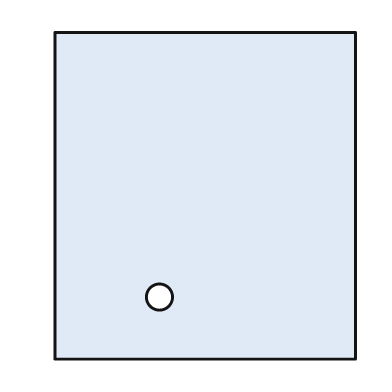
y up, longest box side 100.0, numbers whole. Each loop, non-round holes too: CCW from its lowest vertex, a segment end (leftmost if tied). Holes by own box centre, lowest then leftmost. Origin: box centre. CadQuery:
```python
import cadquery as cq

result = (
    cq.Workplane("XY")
    .moveTo(-46.0, -50.0)
    .lineTo(46.0, -50.0)
    .lineTo(46.0, 50.0)
    .lineTo(-46.0, 50.0)
    .close()
    .moveTo(-14.0, -31.0)
    .circle(4.0)
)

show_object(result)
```